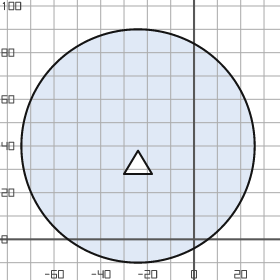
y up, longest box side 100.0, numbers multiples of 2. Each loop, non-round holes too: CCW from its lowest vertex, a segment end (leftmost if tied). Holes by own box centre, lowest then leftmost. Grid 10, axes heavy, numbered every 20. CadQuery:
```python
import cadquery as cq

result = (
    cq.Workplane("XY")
    .moveTo(-24.0, 40.0)
    .circle(50.0)
    .moveTo(-30.0, 28.0)
    .lineTo(-18.0, 28.0)
    .lineTo(-24.0, 38.0)
    .close()
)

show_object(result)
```